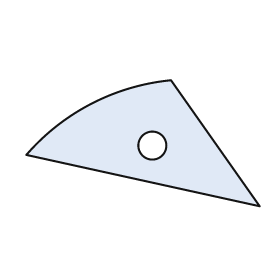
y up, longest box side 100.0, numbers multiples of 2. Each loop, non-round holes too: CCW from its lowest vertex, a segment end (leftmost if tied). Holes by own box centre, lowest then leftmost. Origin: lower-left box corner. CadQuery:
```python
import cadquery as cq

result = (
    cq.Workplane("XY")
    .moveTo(100.0, 0.0)
    .lineTo(62.0, 54.0)
    .threePointArc((28.0, 44.0), (0.0, 22.0))
    .close()
    .moveTo(54.0, 26.0)
    .circle(6.0)
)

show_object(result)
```